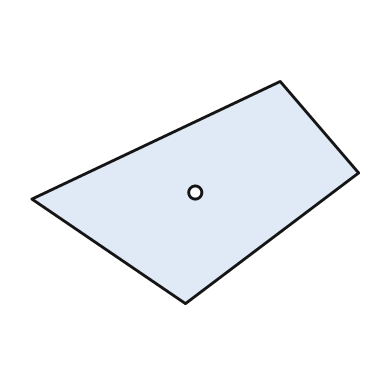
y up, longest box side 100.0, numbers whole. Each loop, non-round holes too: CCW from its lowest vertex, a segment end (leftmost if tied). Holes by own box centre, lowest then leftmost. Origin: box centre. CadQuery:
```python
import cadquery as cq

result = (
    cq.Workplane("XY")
    .moveTo(-3.0, -34.0)
    .lineTo(50.0, 6.0)
    .lineTo(26.0, 34.0)
    .lineTo(-50.0, -2.0)
    .close()
    .moveTo(0.0, 0.0)
    .circle(2.0)
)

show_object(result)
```